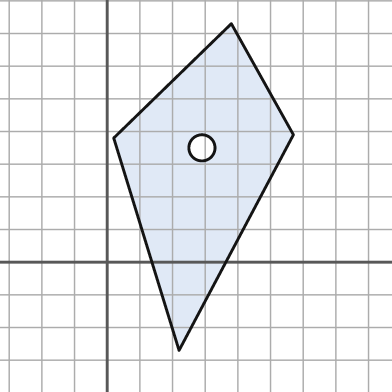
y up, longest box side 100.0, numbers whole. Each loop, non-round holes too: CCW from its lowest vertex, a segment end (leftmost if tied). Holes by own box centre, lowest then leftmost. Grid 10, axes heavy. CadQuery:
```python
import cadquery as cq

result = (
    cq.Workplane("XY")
    .moveTo(22.0, -27.0)
    .lineTo(57.0, 39.0)
    .lineTo(38.0, 73.0)
    .lineTo(2.0, 38.0)
    .close()
    .moveTo(29.0, 35.0)
    .circle(4.0)
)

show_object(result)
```